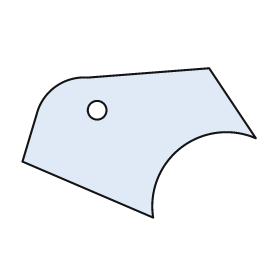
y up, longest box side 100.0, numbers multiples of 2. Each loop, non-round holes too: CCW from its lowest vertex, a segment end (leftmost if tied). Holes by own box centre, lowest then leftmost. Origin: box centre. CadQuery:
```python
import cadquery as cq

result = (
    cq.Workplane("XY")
    .moveTo(6.0, -32.0)
    .threePointArc((18.0, -2.0), (50.0, 2.0))
    .lineTo(30.0, 32.0)
    .lineTo(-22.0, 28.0)
    .threePointArc((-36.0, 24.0), (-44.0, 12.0))
    .lineTo(-50.0, -8.0)
    .close()
    .moveTo(-18.0, 14.0)
    .circle(4.0)
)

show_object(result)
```